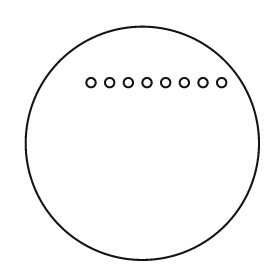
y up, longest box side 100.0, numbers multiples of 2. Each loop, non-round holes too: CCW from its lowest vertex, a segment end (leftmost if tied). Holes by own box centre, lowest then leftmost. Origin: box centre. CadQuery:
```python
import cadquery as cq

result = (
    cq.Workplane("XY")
    .moveTo(0.0, 0.0)
    .circle(50.0)
    .moveTo(-22.0, 26.0)
    .circle(2.0)
    .moveTo(-14.0, 26.0)
    .circle(2.0)
    .moveTo(-6.0, 26.0)
    .circle(2.0)
    .moveTo(2.0, 26.0)
    .circle(2.0)
    .moveTo(10.0, 26.0)
    .circle(2.0)
    .moveTo(18.0, 26.0)
    .circle(2.0)
    .moveTo(26.0, 26.0)
    .circle(2.0)
    .moveTo(34.0, 26.0)
    .circle(2.0)
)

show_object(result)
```